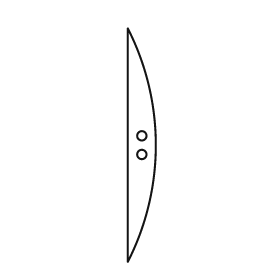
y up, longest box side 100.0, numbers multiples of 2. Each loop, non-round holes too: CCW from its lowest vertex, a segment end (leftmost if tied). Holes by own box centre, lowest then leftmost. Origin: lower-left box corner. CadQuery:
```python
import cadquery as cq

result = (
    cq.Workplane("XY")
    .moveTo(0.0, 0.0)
    .threePointArc((12.0, 50.0), (0.0, 100.0))
    .close()
    .moveTo(6.0, 46.0)
    .circle(2.0)
    .moveTo(6.0, 54.0)
    .circle(2.0)
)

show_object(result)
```